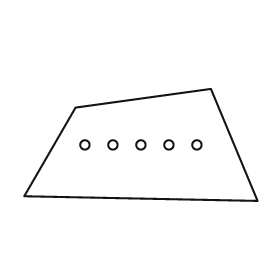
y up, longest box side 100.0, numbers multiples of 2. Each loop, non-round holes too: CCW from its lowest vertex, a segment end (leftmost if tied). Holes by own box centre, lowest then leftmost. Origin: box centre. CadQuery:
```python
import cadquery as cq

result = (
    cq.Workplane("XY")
    .moveTo(50.0, -24.0)
    .lineTo(30.0, 24.0)
    .lineTo(-28.0, 16.0)
    .lineTo(-50.0, -22.0)
    .close()
    .moveTo(-24.0, 0.0)
    .circle(2.0)
    .moveTo(-12.0, 0.0)
    .circle(2.0)
    .moveTo(0.0, 0.0)
    .circle(2.0)
    .moveTo(12.0, 0.0)
    .circle(2.0)
    .moveTo(24.0, 0.0)
    .circle(2.0)
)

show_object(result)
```